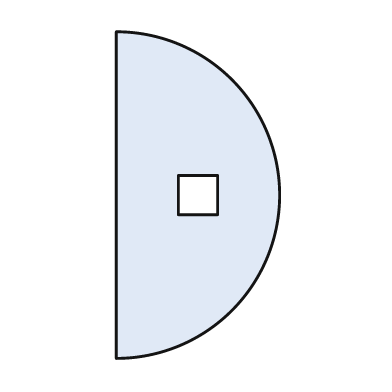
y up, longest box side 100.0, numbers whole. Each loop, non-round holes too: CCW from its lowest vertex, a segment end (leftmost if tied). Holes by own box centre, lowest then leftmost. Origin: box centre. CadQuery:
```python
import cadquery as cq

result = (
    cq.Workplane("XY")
    .moveTo(-25.0, -50.0)
    .threePointArc((25.0, 0.0), (-25.0, 50.0))
    .close()
    .moveTo(-6.0, -6.0)
    .lineTo(6.0, -6.0)
    .lineTo(6.0, 6.0)
    .lineTo(-6.0, 6.0)
    .close()
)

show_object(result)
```